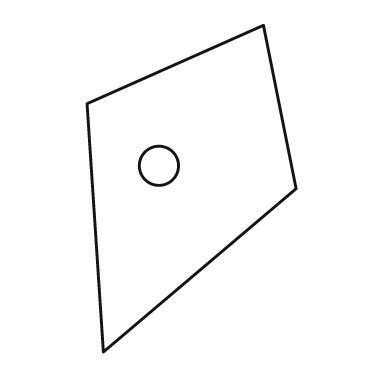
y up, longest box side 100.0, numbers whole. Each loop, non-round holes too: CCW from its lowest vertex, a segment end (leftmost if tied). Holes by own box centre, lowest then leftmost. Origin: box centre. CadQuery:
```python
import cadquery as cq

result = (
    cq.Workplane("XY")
    .moveTo(-27.0, -50.0)
    .lineTo(32.0, 0.0)
    .lineTo(22.0, 50.0)
    .lineTo(-32.0, 26.0)
    .close()
    .moveTo(-10.0, 7.0)
    .circle(6.0)
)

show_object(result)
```